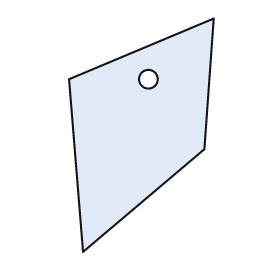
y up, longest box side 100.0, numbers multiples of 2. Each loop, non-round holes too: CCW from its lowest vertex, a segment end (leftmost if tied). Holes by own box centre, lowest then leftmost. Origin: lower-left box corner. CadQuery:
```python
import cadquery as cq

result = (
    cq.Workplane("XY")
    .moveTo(6.0, 0.0)
    .lineTo(58.0, 44.0)
    .lineTo(62.0, 100.0)
    .lineTo(0.0, 74.0)
    .close()
    .moveTo(34.0, 74.0)
    .circle(4.0)
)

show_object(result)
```